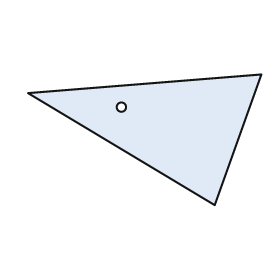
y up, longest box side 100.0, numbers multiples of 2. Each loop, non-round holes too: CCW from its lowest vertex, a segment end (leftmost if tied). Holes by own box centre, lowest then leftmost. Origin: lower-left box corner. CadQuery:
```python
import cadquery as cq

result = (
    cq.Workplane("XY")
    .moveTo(80.0, 0.0)
    .lineTo(100.0, 56.0)
    .lineTo(0.0, 48.0)
    .close()
    .moveTo(40.0, 42.0)
    .circle(2.0)
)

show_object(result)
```